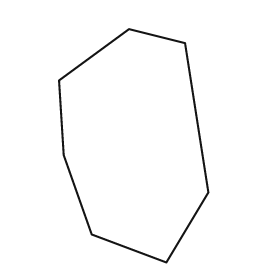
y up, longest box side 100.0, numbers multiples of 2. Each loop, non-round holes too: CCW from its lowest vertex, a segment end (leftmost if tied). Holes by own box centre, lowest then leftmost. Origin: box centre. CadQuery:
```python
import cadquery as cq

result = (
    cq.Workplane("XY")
    .moveTo(14.0, -50.0)
    .lineTo(32.0, -20.0)
    .lineTo(22.0, 44.0)
    .lineTo(-2.0, 50.0)
    .lineTo(-32.0, 28.0)
    .lineTo(-30.0, -4.0)
    .lineTo(-18.0, -38.0)
    .close()
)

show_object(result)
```